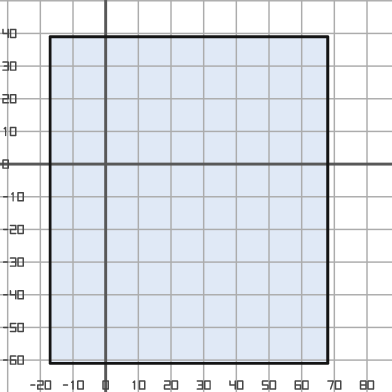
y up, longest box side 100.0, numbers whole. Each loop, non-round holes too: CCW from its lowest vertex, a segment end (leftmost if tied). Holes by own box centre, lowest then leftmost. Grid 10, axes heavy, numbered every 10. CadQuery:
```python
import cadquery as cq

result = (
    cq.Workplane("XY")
    .moveTo(-17.0, -61.0)
    .lineTo(68.0, -61.0)
    .lineTo(68.0, 39.0)
    .lineTo(-17.0, 39.0)
    .close()
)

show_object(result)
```